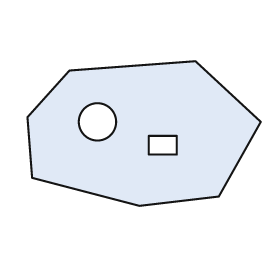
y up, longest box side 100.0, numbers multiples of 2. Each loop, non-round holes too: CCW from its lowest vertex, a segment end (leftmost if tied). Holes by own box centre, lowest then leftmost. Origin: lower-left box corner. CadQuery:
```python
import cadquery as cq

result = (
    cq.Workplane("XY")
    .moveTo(48.0, 0.0)
    .lineTo(82.0, 4.0)
    .lineTo(100.0, 36.0)
    .lineTo(72.0, 62.0)
    .lineTo(18.0, 58.0)
    .lineTo(0.0, 38.0)
    .lineTo(2.0, 12.0)
    .close()
    .moveTo(52.0, 22.0)
    .lineTo(64.0, 22.0)
    .lineTo(64.0, 30.0)
    .lineTo(52.0, 30.0)
    .close()
    .moveTo(30.0, 36.0)
    .circle(8.0)
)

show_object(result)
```